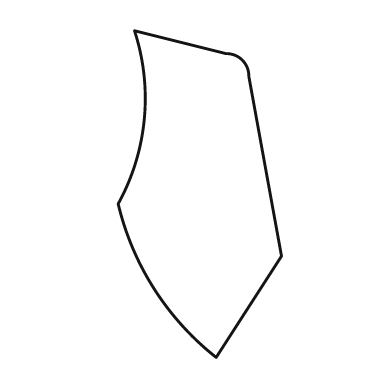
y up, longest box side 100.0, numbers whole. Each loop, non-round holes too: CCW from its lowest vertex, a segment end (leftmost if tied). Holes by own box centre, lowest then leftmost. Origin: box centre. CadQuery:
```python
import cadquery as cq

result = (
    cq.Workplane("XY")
    .moveTo(5.0, -50.0)
    .lineTo(25.0, -19.0)
    .lineTo(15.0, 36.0)
    .threePointArc((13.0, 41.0), (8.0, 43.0))
    .lineTo(-20.0, 50.0)
    .threePointArc((-17.0, 23.0), (-25.0, -3.0))
    .threePointArc((-14.0, -29.0), (5.0, -50.0))
    .close()
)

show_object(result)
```